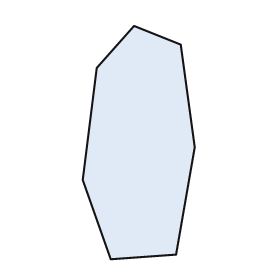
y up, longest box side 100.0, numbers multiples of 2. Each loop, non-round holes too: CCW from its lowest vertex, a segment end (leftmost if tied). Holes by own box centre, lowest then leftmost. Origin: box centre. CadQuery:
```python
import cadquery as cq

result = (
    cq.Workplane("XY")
    .moveTo(-12.0, -50.0)
    .lineTo(16.0, -48.0)
    .lineTo(24.0, -2.0)
    .lineTo(18.0, 42.0)
    .lineTo(-2.0, 50.0)
    .lineTo(-18.0, 32.0)
    .lineTo(-24.0, -16.0)
    .close()
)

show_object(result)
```